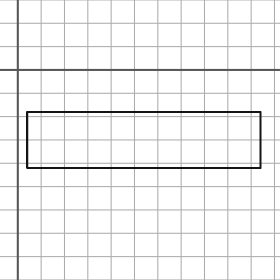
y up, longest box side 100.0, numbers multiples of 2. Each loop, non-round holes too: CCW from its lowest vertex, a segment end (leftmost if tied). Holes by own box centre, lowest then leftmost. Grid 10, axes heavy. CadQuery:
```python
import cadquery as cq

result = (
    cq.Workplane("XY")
    .moveTo(4.0, -42.0)
    .lineTo(104.0, -42.0)
    .lineTo(104.0, -18.0)
    .lineTo(4.0, -18.0)
    .close()
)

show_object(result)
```